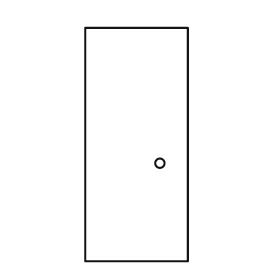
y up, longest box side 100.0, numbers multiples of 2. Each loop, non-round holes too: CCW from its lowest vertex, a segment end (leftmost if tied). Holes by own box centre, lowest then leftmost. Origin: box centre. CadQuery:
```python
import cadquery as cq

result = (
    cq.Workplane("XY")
    .moveTo(-22.0, -50.0)
    .lineTo(22.0, -50.0)
    .lineTo(22.0, 50.0)
    .lineTo(-22.0, 50.0)
    .close()
    .moveTo(10.0, -8.0)
    .circle(2.0)
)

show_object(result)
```